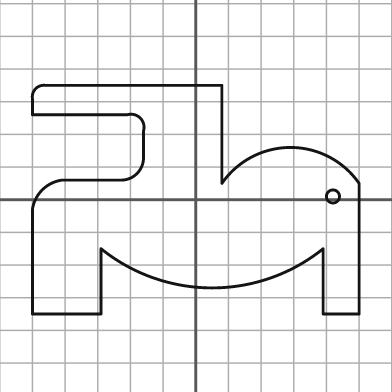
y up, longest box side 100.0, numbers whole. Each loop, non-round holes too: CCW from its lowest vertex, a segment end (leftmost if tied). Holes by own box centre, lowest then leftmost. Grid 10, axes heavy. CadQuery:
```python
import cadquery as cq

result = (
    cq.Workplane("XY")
    .moveTo(-50.0, -35.0)
    .lineTo(-29.0, -35.0)
    .lineTo(-29.0, -15.0)
    .threePointArc((5.0, -27.0), (39.0, -15.0))
    .lineTo(39.0, -35.0)
    .lineTo(50.0, -35.0)
    .lineTo(50.0, 5.0)
    .threePointArc((29.0, 16.0), (8.0, 5.0))
    .lineTo(8.0, 35.0)
    .lineTo(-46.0, 35.0)
    .threePointArc((-49.0, 34.0), (-50.0, 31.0))
    .lineTo(-50.0, 26.0)
    .lineTo(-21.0, 26.0)
    .threePointArc((-17.0, 25.0), (-16.0, 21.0))
    .lineTo(-16.0, 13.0)
    .threePointArc((-18.0, 8.0), (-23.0, 6.0))
    .lineTo(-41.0, 6.0)
    .threePointArc((-47.0, 3.0), (-50.0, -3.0))
    .close()
    .moveTo(42.0, 1.0)
    .circle(2.0)
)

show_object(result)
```